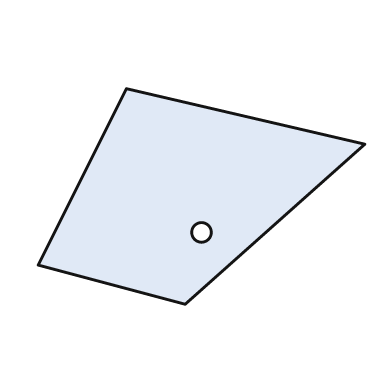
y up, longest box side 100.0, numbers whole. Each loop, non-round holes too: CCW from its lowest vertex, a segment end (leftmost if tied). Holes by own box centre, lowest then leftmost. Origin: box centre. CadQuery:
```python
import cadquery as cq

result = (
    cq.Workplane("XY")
    .moveTo(-5.0, -33.0)
    .lineTo(50.0, 16.0)
    .lineTo(-23.0, 33.0)
    .lineTo(-50.0, -21.0)
    .close()
    .moveTo(0.0, -11.0)
    .circle(3.0)
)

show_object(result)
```